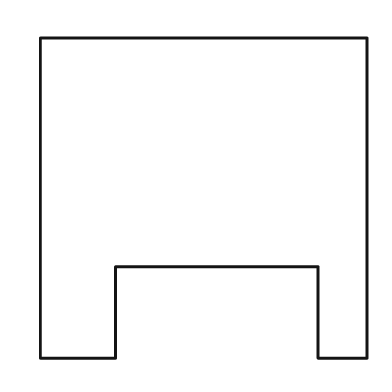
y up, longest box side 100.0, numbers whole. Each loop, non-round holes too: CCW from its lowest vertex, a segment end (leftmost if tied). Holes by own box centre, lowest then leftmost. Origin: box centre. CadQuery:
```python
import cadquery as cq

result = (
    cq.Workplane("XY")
    .moveTo(-50.0, -49.0)
    .lineTo(-27.0, -49.0)
    .lineTo(-27.0, -21.0)
    .lineTo(35.0, -21.0)
    .lineTo(35.0, -49.0)
    .lineTo(50.0, -49.0)
    .lineTo(50.0, 49.0)
    .lineTo(-50.0, 49.0)
    .close()
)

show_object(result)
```